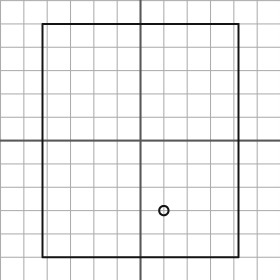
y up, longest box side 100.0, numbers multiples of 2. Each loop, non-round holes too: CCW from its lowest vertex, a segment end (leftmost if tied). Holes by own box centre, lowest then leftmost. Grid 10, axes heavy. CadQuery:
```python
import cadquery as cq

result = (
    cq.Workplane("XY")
    .moveTo(-42.0, -50.0)
    .lineTo(42.0, -50.0)
    .lineTo(42.0, 50.0)
    .lineTo(-42.0, 50.0)
    .close()
    .moveTo(10.0, -30.0)
    .circle(2.0)
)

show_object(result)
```